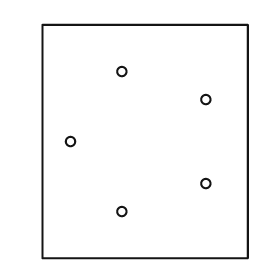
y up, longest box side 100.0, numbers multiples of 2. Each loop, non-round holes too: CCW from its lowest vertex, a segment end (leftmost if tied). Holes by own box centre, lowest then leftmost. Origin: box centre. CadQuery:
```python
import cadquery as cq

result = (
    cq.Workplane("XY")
    .moveTo(-44.0, -50.0)
    .lineTo(44.0, -50.0)
    .lineTo(44.0, 50.0)
    .lineTo(-44.0, 50.0)
    .close()
    .moveTo(-10.0, -30.0)
    .circle(2.0)
    .moveTo(26.0, -18.0)
    .circle(2.0)
    .moveTo(-32.0, 0.0)
    .circle(2.0)
    .moveTo(26.0, 18.0)
    .circle(2.0)
    .moveTo(-10.0, 30.0)
    .circle(2.0)
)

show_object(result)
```